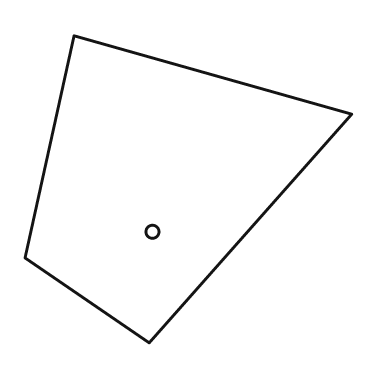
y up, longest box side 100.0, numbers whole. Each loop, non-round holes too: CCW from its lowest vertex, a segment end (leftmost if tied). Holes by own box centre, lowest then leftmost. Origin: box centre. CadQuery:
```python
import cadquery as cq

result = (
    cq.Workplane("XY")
    .moveTo(-12.0, -47.0)
    .lineTo(50.0, 23.0)
    .lineTo(-35.0, 47.0)
    .lineTo(-50.0, -21.0)
    .close()
    .moveTo(-11.0, -13.0)
    .circle(2.0)
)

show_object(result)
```